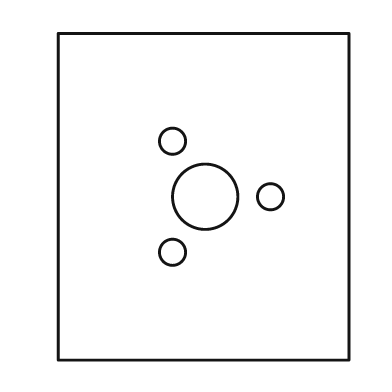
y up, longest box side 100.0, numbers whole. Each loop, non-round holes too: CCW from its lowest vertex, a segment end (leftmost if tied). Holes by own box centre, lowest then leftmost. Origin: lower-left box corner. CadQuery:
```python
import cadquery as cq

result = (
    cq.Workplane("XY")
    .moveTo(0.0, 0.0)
    .lineTo(89.0, 0.0)
    .lineTo(89.0, 100.0)
    .lineTo(0.0, 100.0)
    .close()
    .moveTo(35.0, 33.0)
    .circle(4.0)
    .moveTo(45.0, 50.0)
    .circle(10.0)
    .moveTo(65.0, 50.0)
    .circle(4.0)
    .moveTo(35.0, 67.0)
    .circle(4.0)
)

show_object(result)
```